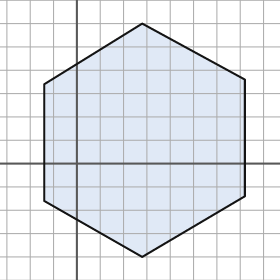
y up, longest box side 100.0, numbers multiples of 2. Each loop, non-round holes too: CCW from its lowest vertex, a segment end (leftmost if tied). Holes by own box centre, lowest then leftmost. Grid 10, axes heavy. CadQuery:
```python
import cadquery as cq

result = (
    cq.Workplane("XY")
    .moveTo(28.0, -40.0)
    .lineTo(72.0, -14.0)
    .lineTo(72.0, 36.0)
    .lineTo(28.0, 60.0)
    .lineTo(-14.0, 34.0)
    .lineTo(-14.0, -16.0)
    .close()
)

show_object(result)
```